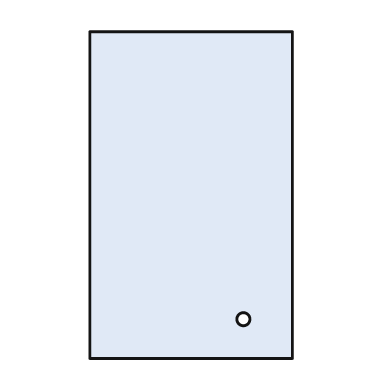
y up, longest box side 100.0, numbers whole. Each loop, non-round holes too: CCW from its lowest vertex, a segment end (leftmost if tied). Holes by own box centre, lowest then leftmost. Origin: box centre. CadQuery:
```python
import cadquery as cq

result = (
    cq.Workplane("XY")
    .moveTo(-31.0, -50.0)
    .lineTo(31.0, -50.0)
    .lineTo(31.0, 50.0)
    .lineTo(-31.0, 50.0)
    .close()
    .moveTo(16.0, -38.0)
    .circle(2.0)
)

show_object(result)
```